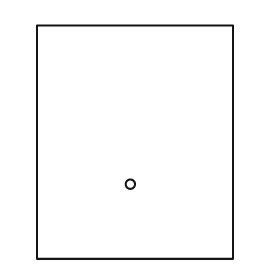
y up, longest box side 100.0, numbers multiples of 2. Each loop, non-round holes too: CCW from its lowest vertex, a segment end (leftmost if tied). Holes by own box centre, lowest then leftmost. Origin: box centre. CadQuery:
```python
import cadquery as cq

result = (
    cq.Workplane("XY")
    .moveTo(-42.0, -50.0)
    .lineTo(42.0, -50.0)
    .lineTo(42.0, 50.0)
    .lineTo(-42.0, 50.0)
    .close()
    .moveTo(-2.0, -18.0)
    .circle(2.0)
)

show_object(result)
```